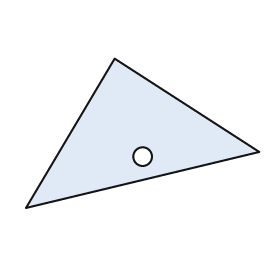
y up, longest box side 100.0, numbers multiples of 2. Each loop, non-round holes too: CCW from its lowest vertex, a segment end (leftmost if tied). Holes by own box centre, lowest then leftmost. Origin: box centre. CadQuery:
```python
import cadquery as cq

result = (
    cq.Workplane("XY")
    .moveTo(-50.0, -32.0)
    .lineTo(50.0, -8.0)
    .lineTo(-12.0, 32.0)
    .close()
    .moveTo(0.0, -10.0)
    .circle(4.0)
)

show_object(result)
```